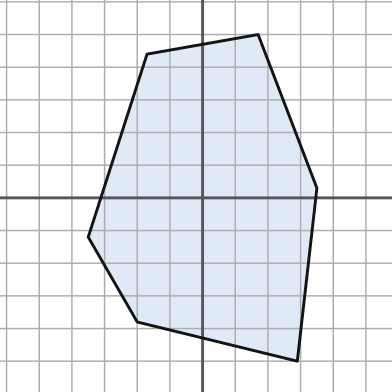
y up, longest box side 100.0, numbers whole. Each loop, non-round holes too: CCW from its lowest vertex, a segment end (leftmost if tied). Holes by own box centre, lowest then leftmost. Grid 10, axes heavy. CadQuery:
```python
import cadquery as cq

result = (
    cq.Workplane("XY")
    .moveTo(29.0, -50.0)
    .lineTo(35.0, 3.0)
    .lineTo(17.0, 50.0)
    .lineTo(-17.0, 44.0)
    .lineTo(-35.0, -12.0)
    .lineTo(-20.0, -38.0)
    .close()
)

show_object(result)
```